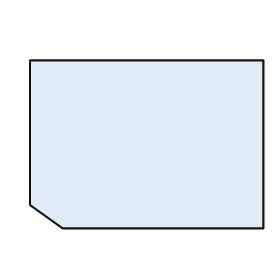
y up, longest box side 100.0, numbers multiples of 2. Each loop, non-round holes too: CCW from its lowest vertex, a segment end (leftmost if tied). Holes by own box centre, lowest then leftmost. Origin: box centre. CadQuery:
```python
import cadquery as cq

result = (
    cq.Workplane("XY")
    .moveTo(-36.0, -36.0)
    .lineTo(50.0, -36.0)
    .lineTo(50.0, 36.0)
    .lineTo(-50.0, 36.0)
    .lineTo(-50.0, -26.0)
    .close()
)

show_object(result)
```